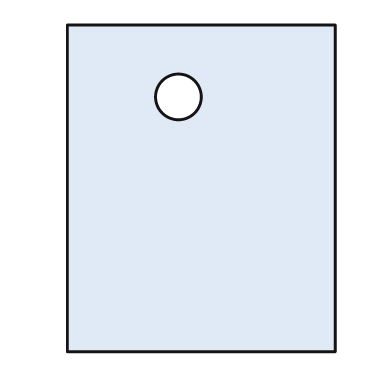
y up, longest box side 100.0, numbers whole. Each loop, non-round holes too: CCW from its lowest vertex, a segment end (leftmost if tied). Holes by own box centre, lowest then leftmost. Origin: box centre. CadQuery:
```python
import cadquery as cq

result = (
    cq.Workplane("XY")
    .moveTo(-41.0, -50.0)
    .lineTo(41.0, -50.0)
    .lineTo(41.0, 50.0)
    .lineTo(-41.0, 50.0)
    .close()
    .moveTo(-7.0, 28.0)
    .circle(7.0)
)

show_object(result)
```